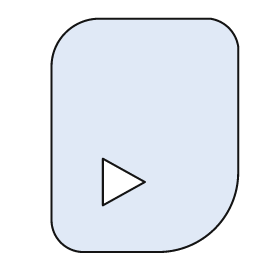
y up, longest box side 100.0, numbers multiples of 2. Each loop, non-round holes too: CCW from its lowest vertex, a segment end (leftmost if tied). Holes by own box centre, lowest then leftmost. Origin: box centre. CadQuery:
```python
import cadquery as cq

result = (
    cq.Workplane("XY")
    .moveTo(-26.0, -50.0)
    .lineTo(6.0, -50.0)
    .threePointArc((30.0, -40.0), (40.0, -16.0))
    .lineTo(40.0, 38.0)
    .threePointArc((36.0, 46.0), (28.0, 50.0))
    .lineTo(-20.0, 50.0)
    .threePointArc((-34.0, 44.0), (-40.0, 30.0))
    .lineTo(-40.0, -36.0)
    .threePointArc((-36.0, -46.0), (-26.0, -50.0))
    .close()
    .moveTo(-18.0, -30.0)
    .lineTo(0.0, -20.0)
    .lineTo(-18.0, -10.0)
    .close()
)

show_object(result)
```